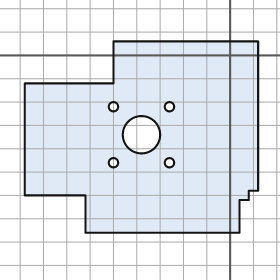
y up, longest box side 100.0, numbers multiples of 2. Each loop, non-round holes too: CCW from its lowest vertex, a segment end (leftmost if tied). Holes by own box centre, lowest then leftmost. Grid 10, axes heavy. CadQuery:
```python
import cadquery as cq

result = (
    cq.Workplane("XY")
    .moveTo(-62.0, -76.0)
    .lineTo(4.0, -76.0)
    .lineTo(4.0, -62.0)
    .lineTo(8.0, -62.0)
    .lineTo(8.0, -58.0)
    .lineTo(12.0, -58.0)
    .lineTo(12.0, 6.0)
    .lineTo(-50.0, 6.0)
    .lineTo(-50.0, -12.0)
    .lineTo(-88.0, -12.0)
    .lineTo(-88.0, -60.0)
    .lineTo(-62.0, -60.0)
    .close()
    .moveTo(-50.0, -46.0)
    .circle(2.0)
    .moveTo(-26.0, -46.0)
    .circle(2.0)
    .moveTo(-38.0, -34.0)
    .circle(8.0)
    .moveTo(-50.0, -22.0)
    .circle(2.0)
    .moveTo(-26.0, -22.0)
    .circle(2.0)
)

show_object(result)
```